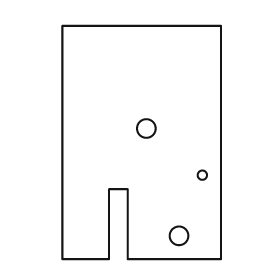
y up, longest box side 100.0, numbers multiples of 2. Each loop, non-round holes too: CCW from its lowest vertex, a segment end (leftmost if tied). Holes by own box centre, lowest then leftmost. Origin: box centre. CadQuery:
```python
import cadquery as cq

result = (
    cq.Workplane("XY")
    .moveTo(-34.0, -50.0)
    .lineTo(-14.0, -50.0)
    .lineTo(-14.0, -20.0)
    .lineTo(-6.0, -20.0)
    .lineTo(-6.0, -50.0)
    .lineTo(34.0, -50.0)
    .lineTo(34.0, 50.0)
    .lineTo(-34.0, 50.0)
    .close()
    .moveTo(16.0, -40.0)
    .circle(4.0)
    .moveTo(26.0, -14.0)
    .circle(2.0)
    .moveTo(2.0, 6.0)
    .circle(4.0)
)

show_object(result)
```